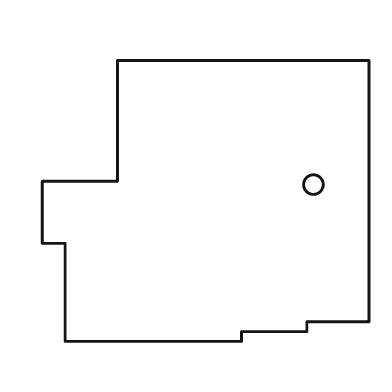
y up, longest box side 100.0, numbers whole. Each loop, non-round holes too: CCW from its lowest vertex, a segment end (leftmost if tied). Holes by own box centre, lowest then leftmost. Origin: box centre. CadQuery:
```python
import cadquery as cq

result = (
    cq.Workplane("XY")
    .moveTo(-43.0, -43.0)
    .lineTo(11.0, -43.0)
    .lineTo(11.0, -40.0)
    .lineTo(31.0, -40.0)
    .lineTo(31.0, -37.0)
    .lineTo(50.0, -37.0)
    .lineTo(50.0, 43.0)
    .lineTo(-27.0, 43.0)
    .lineTo(-27.0, 6.0)
    .lineTo(-50.0, 6.0)
    .lineTo(-50.0, -13.0)
    .lineTo(-43.0, -13.0)
    .close()
    .moveTo(33.0, 5.0)
    .circle(3.0)
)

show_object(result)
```